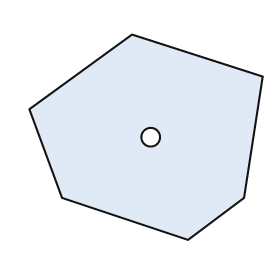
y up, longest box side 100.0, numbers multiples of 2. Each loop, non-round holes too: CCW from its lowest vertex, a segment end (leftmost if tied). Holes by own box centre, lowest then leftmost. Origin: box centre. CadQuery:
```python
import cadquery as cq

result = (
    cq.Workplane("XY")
    .moveTo(18.0, -44.0)
    .lineTo(42.0, -26.0)
    .lineTo(50.0, 26.0)
    .lineTo(-6.0, 44.0)
    .lineTo(-50.0, 12.0)
    .lineTo(-36.0, -26.0)
    .close()
    .moveTo(2.0, 0.0)
    .circle(4.0)
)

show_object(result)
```